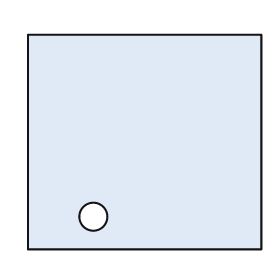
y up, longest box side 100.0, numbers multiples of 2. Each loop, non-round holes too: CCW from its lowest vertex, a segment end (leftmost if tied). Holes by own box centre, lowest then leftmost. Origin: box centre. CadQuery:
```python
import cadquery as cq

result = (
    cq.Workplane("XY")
    .moveTo(-50.0, -46.0)
    .lineTo(50.0, -46.0)
    .lineTo(50.0, 46.0)
    .lineTo(-50.0, 46.0)
    .close()
    .moveTo(-22.0, -32.0)
    .circle(6.0)
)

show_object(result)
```